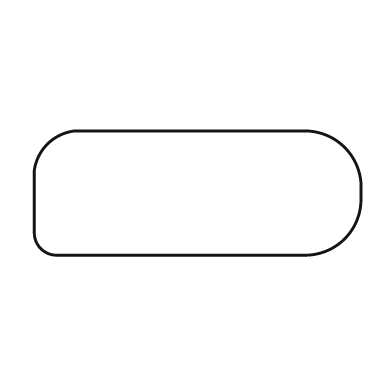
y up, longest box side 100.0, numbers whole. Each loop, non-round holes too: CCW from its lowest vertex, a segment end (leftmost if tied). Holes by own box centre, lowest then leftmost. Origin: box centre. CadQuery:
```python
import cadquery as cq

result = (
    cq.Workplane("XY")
    .moveTo(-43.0, -19.0)
    .lineTo(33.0, -19.0)
    .threePointArc((45.0, -14.0), (50.0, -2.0))
    .lineTo(50.0, 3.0)
    .threePointArc((45.0, 14.0), (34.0, 19.0))
    .lineTo(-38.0, 19.0)
    .threePointArc((-46.0, 15.0), (-50.0, 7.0))
    .lineTo(-50.0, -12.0)
    .threePointArc((-48.0, -17.0), (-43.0, -19.0))
    .close()
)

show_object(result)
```